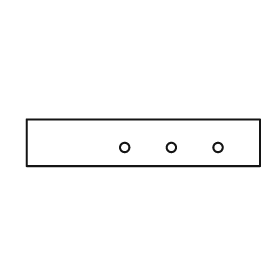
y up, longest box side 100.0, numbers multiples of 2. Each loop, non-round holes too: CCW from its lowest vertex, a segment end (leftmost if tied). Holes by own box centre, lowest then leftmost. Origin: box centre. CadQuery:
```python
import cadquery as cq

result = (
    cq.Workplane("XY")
    .moveTo(-50.0, -10.0)
    .lineTo(50.0, -10.0)
    .lineTo(50.0, 10.0)
    .lineTo(-50.0, 10.0)
    .close()
    .moveTo(-8.0, -2.0)
    .circle(2.0)
    .moveTo(12.0, -2.0)
    .circle(2.0)
    .moveTo(32.0, -2.0)
    .circle(2.0)
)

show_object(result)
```